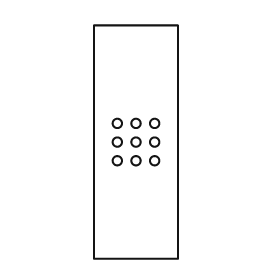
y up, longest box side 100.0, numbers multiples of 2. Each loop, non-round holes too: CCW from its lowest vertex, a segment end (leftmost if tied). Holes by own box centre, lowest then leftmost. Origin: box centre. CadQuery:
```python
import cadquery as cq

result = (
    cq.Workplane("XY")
    .moveTo(-18.0, -50.0)
    .lineTo(18.0, -50.0)
    .lineTo(18.0, 50.0)
    .lineTo(-18.0, 50.0)
    .close()
    .moveTo(-8.0, -8.0)
    .circle(2.0)
    .moveTo(0.0, -8.0)
    .circle(2.0)
    .moveTo(8.0, -8.0)
    .circle(2.0)
    .moveTo(-8.0, 0.0)
    .circle(2.0)
    .moveTo(0.0, 0.0)
    .circle(2.0)
    .moveTo(8.0, 0.0)
    .circle(2.0)
    .moveTo(-8.0, 8.0)
    .circle(2.0)
    .moveTo(0.0, 8.0)
    .circle(2.0)
    .moveTo(8.0, 8.0)
    .circle(2.0)
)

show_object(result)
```